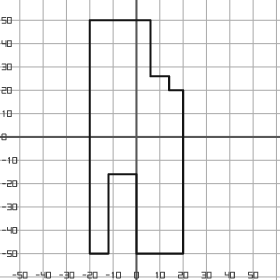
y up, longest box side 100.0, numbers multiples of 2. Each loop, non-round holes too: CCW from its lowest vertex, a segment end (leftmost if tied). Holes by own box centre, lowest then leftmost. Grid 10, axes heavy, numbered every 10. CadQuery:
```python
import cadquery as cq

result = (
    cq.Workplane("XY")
    .moveTo(-20.0, -50.0)
    .lineTo(-12.0, -50.0)
    .lineTo(-12.0, -16.0)
    .lineTo(0.0, -16.0)
    .lineTo(0.0, -50.0)
    .lineTo(20.0, -50.0)
    .lineTo(20.0, 20.0)
    .lineTo(14.0, 20.0)
    .lineTo(14.0, 26.0)
    .lineTo(6.0, 26.0)
    .lineTo(6.0, 50.0)
    .lineTo(-20.0, 50.0)
    .close()
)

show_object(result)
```